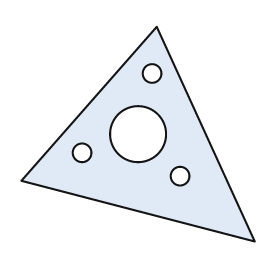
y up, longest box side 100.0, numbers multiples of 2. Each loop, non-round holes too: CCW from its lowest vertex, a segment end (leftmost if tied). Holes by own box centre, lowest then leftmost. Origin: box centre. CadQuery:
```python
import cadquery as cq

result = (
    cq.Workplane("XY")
    .moveTo(50.0, -46.0)
    .lineTo(8.0, 46.0)
    .lineTo(-50.0, -20.0)
    .close()
    .moveTo(18.0, -18.0)
    .circle(4.0)
    .moveTo(-24.0, -8.0)
    .circle(4.0)
    .moveTo(0.0, 0.0)
    .circle(12.0)
    .moveTo(6.0, 26.0)
    .circle(4.0)
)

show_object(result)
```